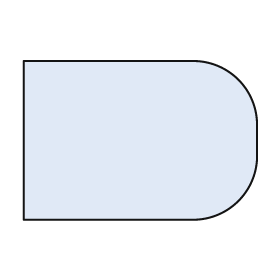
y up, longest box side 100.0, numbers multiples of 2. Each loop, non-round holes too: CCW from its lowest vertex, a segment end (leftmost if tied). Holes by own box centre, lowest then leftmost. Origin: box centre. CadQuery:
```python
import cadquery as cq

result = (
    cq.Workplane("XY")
    .moveTo(-50.0, -34.0)
    .lineTo(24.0, -34.0)
    .threePointArc((42.0, -26.0), (50.0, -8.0))
    .lineTo(50.0, 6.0)
    .threePointArc((42.0, 26.0), (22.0, 34.0))
    .lineTo(-50.0, 34.0)
    .close()
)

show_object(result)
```